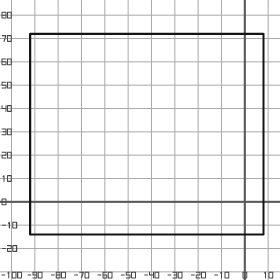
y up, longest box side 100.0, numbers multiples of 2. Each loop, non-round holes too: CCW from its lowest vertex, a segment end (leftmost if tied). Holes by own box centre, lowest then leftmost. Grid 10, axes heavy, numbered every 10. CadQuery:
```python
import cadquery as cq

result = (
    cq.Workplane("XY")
    .moveTo(-92.0, -14.0)
    .lineTo(8.0, -14.0)
    .lineTo(8.0, 72.0)
    .lineTo(-92.0, 72.0)
    .close()
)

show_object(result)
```